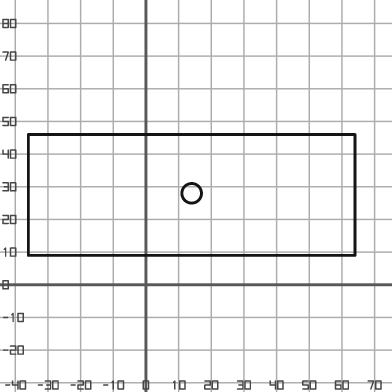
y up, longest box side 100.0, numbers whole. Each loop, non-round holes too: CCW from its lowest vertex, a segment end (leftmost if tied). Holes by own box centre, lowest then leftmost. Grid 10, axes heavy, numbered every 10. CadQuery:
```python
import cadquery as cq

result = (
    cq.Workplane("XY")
    .moveTo(-36.0, 9.0)
    .lineTo(64.0, 9.0)
    .lineTo(64.0, 46.0)
    .lineTo(-36.0, 46.0)
    .close()
    .moveTo(14.0, 28.0)
    .circle(3.0)
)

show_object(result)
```